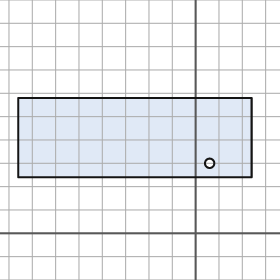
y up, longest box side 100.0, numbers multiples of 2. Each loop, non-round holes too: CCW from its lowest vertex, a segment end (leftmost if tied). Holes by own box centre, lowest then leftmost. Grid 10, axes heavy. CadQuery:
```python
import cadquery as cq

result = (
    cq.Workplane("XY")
    .moveTo(-76.0, 24.0)
    .lineTo(24.0, 24.0)
    .lineTo(24.0, 58.0)
    .lineTo(-76.0, 58.0)
    .close()
    .moveTo(6.0, 30.0)
    .circle(2.0)
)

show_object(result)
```